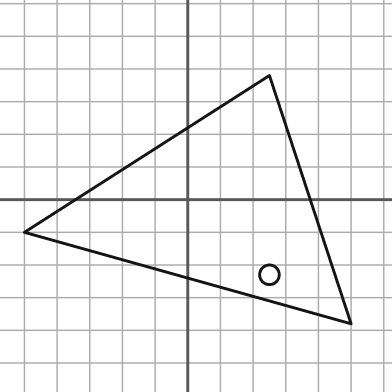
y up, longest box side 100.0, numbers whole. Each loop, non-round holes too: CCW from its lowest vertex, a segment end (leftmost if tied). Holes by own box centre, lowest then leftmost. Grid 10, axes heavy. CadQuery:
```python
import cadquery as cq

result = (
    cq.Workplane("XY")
    .moveTo(50.0, -38.0)
    .lineTo(25.0, 38.0)
    .lineTo(-50.0, -10.0)
    .close()
    .moveTo(25.0, -23.0)
    .circle(3.0)
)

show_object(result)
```